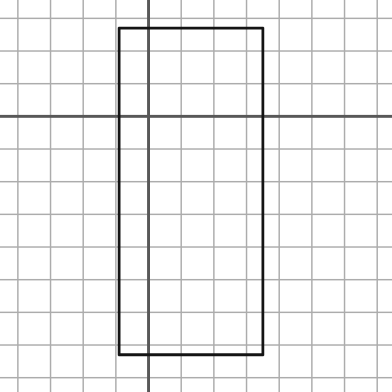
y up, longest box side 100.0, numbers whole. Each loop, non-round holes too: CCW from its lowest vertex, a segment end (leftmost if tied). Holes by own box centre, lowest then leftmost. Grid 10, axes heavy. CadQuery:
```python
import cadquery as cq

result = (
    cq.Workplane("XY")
    .moveTo(-9.0, -73.0)
    .lineTo(35.0, -73.0)
    .lineTo(35.0, 27.0)
    .lineTo(-9.0, 27.0)
    .close()
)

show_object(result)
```